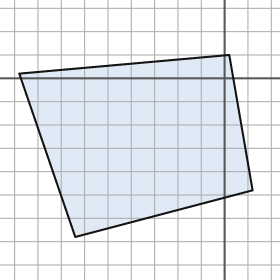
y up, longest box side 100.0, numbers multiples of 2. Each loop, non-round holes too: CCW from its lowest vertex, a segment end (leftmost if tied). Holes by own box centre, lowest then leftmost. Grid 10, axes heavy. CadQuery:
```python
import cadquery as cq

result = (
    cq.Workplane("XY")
    .moveTo(-64.0, -68.0)
    .lineTo(12.0, -48.0)
    .lineTo(2.0, 10.0)
    .lineTo(-88.0, 2.0)
    .close()
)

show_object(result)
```